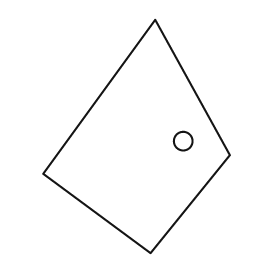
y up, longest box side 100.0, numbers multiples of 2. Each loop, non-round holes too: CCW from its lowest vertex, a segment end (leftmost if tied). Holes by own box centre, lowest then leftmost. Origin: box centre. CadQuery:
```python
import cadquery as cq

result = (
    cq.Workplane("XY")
    .moveTo(6.0, -50.0)
    .lineTo(40.0, -8.0)
    .lineTo(8.0, 50.0)
    .lineTo(-40.0, -16.0)
    .close()
    .moveTo(20.0, -2.0)
    .circle(4.0)
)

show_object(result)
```